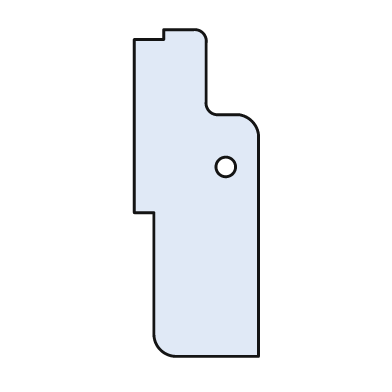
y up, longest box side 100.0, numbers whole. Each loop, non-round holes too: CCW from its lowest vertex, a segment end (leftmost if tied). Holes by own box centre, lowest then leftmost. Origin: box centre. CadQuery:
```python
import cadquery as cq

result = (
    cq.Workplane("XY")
    .moveTo(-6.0, -50.0)
    .lineTo(19.0, -50.0)
    .lineTo(19.0, 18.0)
    .threePointArc((17.0, 22.0), (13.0, 24.0))
    .lineTo(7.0, 24.0)
    .threePointArc((4.0, 25.0), (3.0, 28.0))
    .lineTo(3.0, 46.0)
    .threePointArc((2.0, 49.0), (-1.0, 50.0))
    .lineTo(-10.0, 50.0)
    .lineTo(-10.0, 47.0)
    .lineTo(-19.0, 47.0)
    .lineTo(-19.0, -6.0)
    .lineTo(-13.0, -6.0)
    .lineTo(-13.0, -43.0)
    .threePointArc((-11.0, -48.0), (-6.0, -50.0))
    .close()
    .moveTo(9.0, 8.0)
    .circle(3.0)
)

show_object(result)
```